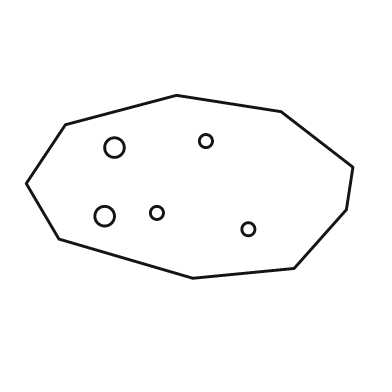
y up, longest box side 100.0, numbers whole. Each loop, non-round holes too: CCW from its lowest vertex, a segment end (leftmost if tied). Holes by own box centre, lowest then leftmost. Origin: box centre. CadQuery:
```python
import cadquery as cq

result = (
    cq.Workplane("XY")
    .moveTo(1.0, -28.0)
    .lineTo(32.0, -25.0)
    .lineTo(48.0, -7.0)
    .lineTo(50.0, 6.0)
    .lineTo(28.0, 23.0)
    .lineTo(-4.0, 28.0)
    .lineTo(-38.0, 19.0)
    .lineTo(-50.0, 1.0)
    .lineTo(-40.0, -16.0)
    .close()
    .moveTo(18.0, -13.0)
    .circle(2.0)
    .moveTo(-26.0, -9.0)
    .circle(3.0)
    .moveTo(-10.0, -8.0)
    .circle(2.0)
    .moveTo(-23.0, 12.0)
    .circle(3.0)
    .moveTo(5.0, 14.0)
    .circle(2.0)
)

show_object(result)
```